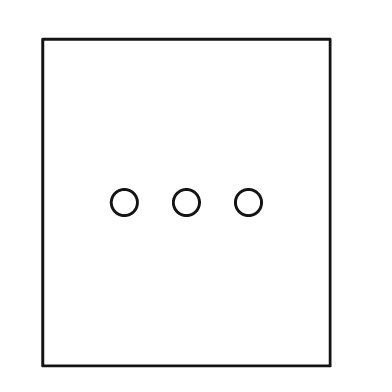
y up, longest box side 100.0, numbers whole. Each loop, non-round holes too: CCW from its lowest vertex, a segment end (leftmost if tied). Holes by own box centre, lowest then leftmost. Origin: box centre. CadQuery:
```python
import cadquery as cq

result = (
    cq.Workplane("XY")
    .moveTo(-44.0, -50.0)
    .lineTo(44.0, -50.0)
    .lineTo(44.0, 50.0)
    .lineTo(-44.0, 50.0)
    .close()
    .moveTo(-19.0, 0.0)
    .circle(4.0)
    .moveTo(0.0, 0.0)
    .circle(4.0)
    .moveTo(19.0, 0.0)
    .circle(4.0)
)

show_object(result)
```